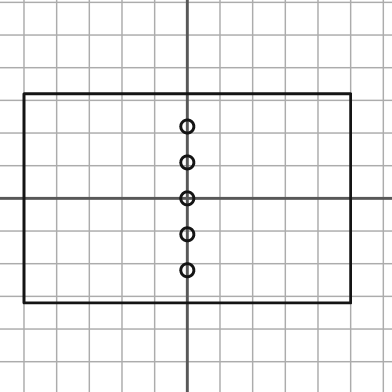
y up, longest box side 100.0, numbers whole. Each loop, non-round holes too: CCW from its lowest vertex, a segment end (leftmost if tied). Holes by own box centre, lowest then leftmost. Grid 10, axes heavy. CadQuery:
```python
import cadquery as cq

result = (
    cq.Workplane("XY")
    .moveTo(-50.0, -32.0)
    .lineTo(50.0, -32.0)
    .lineTo(50.0, 32.0)
    .lineTo(-50.0, 32.0)
    .close()
    .moveTo(0.0, -22.0)
    .circle(2.0)
    .moveTo(0.0, -11.0)
    .circle(2.0)
    .moveTo(0.0, 0.0)
    .circle(2.0)
    .moveTo(0.0, 11.0)
    .circle(2.0)
    .moveTo(0.0, 22.0)
    .circle(2.0)
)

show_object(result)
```